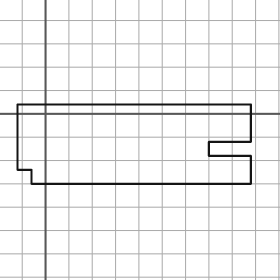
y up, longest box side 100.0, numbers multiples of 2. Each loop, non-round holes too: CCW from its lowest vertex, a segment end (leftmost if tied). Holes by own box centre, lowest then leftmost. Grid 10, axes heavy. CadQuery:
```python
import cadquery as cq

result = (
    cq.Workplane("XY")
    .moveTo(-6.0, -30.0)
    .lineTo(88.0, -30.0)
    .lineTo(88.0, -18.0)
    .lineTo(70.0, -18.0)
    .lineTo(70.0, -12.0)
    .lineTo(88.0, -12.0)
    .lineTo(88.0, 4.0)
    .lineTo(-12.0, 4.0)
    .lineTo(-12.0, -24.0)
    .lineTo(-6.0, -24.0)
    .close()
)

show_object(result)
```